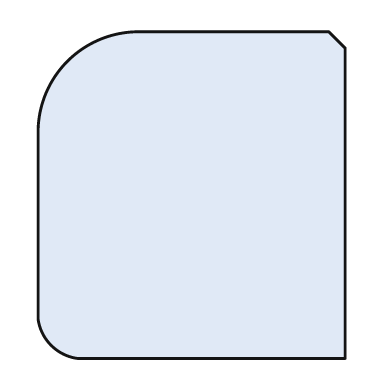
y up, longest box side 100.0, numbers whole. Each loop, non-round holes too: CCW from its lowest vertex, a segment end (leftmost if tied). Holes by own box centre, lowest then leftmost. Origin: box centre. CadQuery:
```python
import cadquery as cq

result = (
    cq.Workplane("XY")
    .moveTo(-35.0, -50.0)
    .lineTo(47.0, -50.0)
    .lineTo(47.0, 45.0)
    .lineTo(42.0, 50.0)
    .lineTo(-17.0, 50.0)
    .threePointArc((-38.0, 41.0), (-47.0, 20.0))
    .lineTo(-47.0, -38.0)
    .threePointArc((-43.0, -46.0), (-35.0, -50.0))
    .close()
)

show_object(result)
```